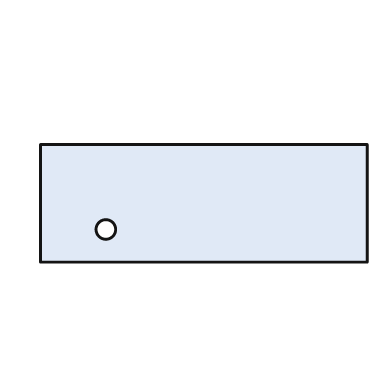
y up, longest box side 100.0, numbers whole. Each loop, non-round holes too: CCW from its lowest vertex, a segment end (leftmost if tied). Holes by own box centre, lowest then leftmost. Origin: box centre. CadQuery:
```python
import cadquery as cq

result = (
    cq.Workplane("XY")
    .moveTo(-50.0, -18.0)
    .lineTo(50.0, -18.0)
    .lineTo(50.0, 18.0)
    .lineTo(-50.0, 18.0)
    .close()
    .moveTo(-30.0, -8.0)
    .circle(3.0)
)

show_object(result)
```